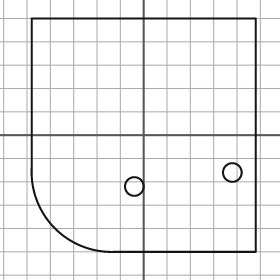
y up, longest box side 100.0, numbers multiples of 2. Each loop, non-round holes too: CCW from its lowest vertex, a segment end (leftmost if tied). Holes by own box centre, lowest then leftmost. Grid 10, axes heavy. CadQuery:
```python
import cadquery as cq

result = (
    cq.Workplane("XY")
    .moveTo(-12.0, -50.0)
    .lineTo(48.0, -50.0)
    .lineTo(48.0, 50.0)
    .lineTo(-48.0, 50.0)
    .lineTo(-48.0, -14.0)
    .threePointArc((-38.0, -40.0), (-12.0, -50.0))
    .close()
    .moveTo(-4.0, -22.0)
    .circle(4.0)
    .moveTo(38.0, -16.0)
    .circle(4.0)
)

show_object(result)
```